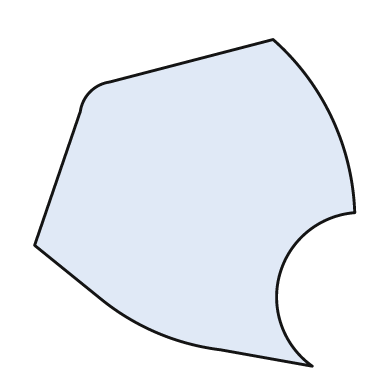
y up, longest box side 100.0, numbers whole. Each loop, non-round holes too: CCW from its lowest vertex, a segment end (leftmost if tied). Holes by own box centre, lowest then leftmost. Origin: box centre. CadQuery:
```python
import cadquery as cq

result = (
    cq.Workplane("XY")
    .moveTo(36.0, -50.0)
    .threePointArc((26.0, -22.0), (49.0, -3.0))
    .threePointArc((42.0, 26.0), (24.0, 50.0))
    .lineTo(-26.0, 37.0)
    .threePointArc((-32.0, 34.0), (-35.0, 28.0))
    .lineTo(-49.0, -13.0)
    .lineTo(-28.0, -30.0)
    .threePointArc((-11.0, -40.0), (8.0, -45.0))
    .close()
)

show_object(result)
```